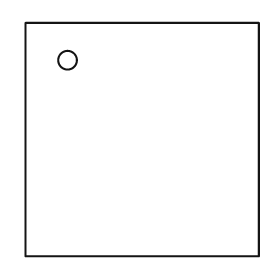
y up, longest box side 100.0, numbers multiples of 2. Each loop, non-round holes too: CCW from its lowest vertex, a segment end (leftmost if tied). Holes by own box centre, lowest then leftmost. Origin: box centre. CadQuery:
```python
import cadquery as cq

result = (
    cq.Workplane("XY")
    .moveTo(-50.0, -50.0)
    .lineTo(50.0, -50.0)
    .lineTo(50.0, 50.0)
    .lineTo(-50.0, 50.0)
    .close()
    .moveTo(-32.0, 34.0)
    .circle(4.0)
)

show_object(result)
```